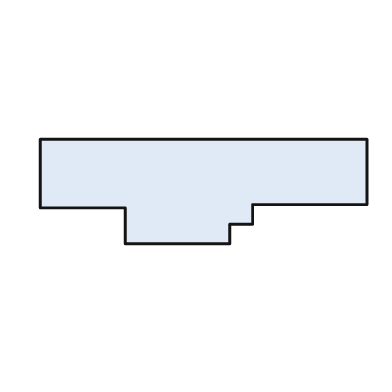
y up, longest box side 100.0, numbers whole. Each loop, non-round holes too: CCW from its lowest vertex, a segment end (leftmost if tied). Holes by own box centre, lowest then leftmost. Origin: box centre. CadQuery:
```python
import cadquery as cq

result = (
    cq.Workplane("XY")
    .moveTo(-24.0, -16.0)
    .lineTo(8.0, -16.0)
    .lineTo(8.0, -10.0)
    .lineTo(15.0, -10.0)
    .lineTo(15.0, -4.0)
    .lineTo(50.0, -4.0)
    .lineTo(50.0, 16.0)
    .lineTo(-50.0, 16.0)
    .lineTo(-50.0, -5.0)
    .lineTo(-24.0, -5.0)
    .close()
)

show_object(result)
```